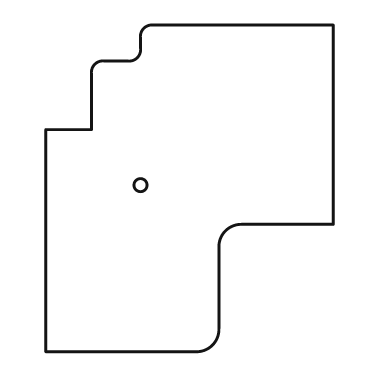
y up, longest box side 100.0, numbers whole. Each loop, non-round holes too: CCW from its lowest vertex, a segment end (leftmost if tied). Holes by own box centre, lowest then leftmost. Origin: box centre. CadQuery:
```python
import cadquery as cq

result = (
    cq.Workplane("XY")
    .moveTo(-44.0, -50.0)
    .lineTo(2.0, -50.0)
    .threePointArc((7.0, -48.0), (9.0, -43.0))
    .lineTo(9.0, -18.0)
    .threePointArc((11.0, -13.0), (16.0, -11.0))
    .lineTo(44.0, -11.0)
    .lineTo(44.0, 50.0)
    .lineTo(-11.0, 50.0)
    .threePointArc((-14.0, 49.0), (-15.0, 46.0))
    .lineTo(-15.0, 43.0)
    .threePointArc((-16.0, 40.0), (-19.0, 39.0))
    .lineTo(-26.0, 39.0)
    .threePointArc((-29.0, 38.0), (-30.0, 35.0))
    .lineTo(-30.0, 18.0)
    .lineTo(-44.0, 18.0)
    .close()
    .moveTo(-15.0, 1.0)
    .circle(2.0)
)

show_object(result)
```